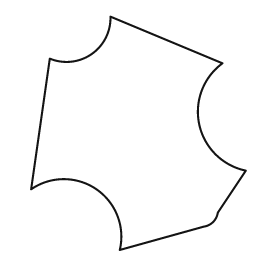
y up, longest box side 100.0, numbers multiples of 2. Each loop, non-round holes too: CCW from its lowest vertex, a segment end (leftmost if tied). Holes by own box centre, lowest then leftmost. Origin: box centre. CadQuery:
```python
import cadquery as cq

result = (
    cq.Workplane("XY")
    .moveTo(-8.0, -50.0)
    .lineTo(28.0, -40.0)
    .threePointArc((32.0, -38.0), (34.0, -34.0))
    .lineTo(46.0, -16.0)
    .threePointArc((26.0, 4.0), (36.0, 30.0))
    .lineTo(-12.0, 50.0)
    .threePointArc((-20.0, 34.0), (-38.0, 32.0))
    .lineTo(-46.0, -24.0)
    .threePointArc((-18.0, -24.0), (-8.0, -50.0))
    .close()
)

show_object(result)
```